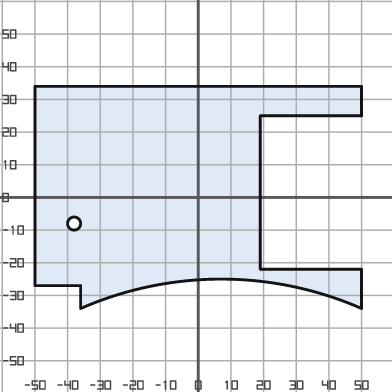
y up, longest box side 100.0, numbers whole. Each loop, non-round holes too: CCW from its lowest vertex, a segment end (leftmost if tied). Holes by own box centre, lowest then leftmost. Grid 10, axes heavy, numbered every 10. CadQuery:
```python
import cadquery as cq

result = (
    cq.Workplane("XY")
    .moveTo(-36.0, -34.0)
    .threePointArc((7.0, -25.0), (50.0, -34.0))
    .lineTo(50.0, -22.0)
    .lineTo(19.0, -22.0)
    .lineTo(19.0, 25.0)
    .lineTo(50.0, 25.0)
    .lineTo(50.0, 34.0)
    .lineTo(-50.0, 34.0)
    .lineTo(-50.0, -27.0)
    .lineTo(-36.0, -27.0)
    .close()
    .moveTo(-38.0, -8.0)
    .circle(2.0)
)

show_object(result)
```